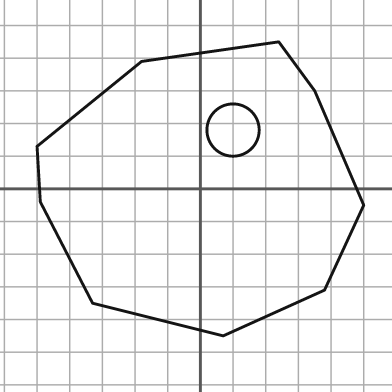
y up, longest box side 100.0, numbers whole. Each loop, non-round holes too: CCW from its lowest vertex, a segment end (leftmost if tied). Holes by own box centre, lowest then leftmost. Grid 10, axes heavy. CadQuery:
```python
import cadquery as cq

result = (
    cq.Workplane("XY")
    .moveTo(7.0, -45.0)
    .lineTo(38.0, -31.0)
    .lineTo(50.0, -5.0)
    .lineTo(35.0, 30.0)
    .lineTo(24.0, 45.0)
    .lineTo(-18.0, 39.0)
    .lineTo(-50.0, 13.0)
    .lineTo(-49.0, -4.0)
    .lineTo(-33.0, -35.0)
    .close()
    .moveTo(10.0, 18.0)
    .circle(8.0)
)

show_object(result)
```